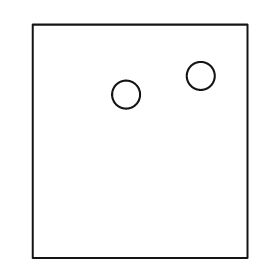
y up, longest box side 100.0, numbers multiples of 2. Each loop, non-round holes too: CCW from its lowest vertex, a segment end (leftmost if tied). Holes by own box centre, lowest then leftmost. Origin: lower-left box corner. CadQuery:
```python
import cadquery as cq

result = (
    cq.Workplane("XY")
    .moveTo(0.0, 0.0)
    .lineTo(92.0, 0.0)
    .lineTo(92.0, 100.0)
    .lineTo(0.0, 100.0)
    .close()
    .moveTo(40.0, 70.0)
    .circle(6.0)
    .moveTo(72.0, 78.0)
    .circle(6.0)
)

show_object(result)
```